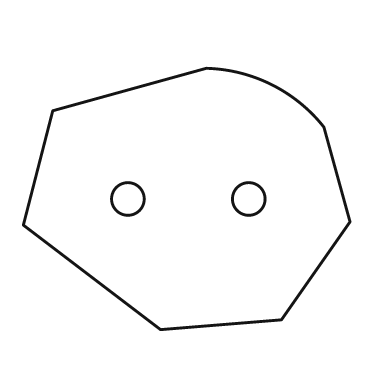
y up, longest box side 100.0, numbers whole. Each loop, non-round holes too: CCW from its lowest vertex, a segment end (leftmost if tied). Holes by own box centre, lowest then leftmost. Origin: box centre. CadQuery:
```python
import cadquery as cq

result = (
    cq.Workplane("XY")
    .moveTo(-8.0, -40.0)
    .lineTo(29.0, -37.0)
    .lineTo(50.0, -7.0)
    .lineTo(42.0, 22.0)
    .threePointArc((26.0, 35.0), (6.0, 40.0))
    .lineTo(-41.0, 27.0)
    .lineTo(-50.0, -8.0)
    .close()
    .moveTo(-18.0, 0.0)
    .circle(5.0)
    .moveTo(19.0, 0.0)
    .circle(5.0)
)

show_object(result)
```